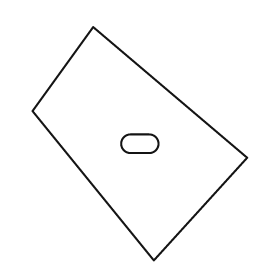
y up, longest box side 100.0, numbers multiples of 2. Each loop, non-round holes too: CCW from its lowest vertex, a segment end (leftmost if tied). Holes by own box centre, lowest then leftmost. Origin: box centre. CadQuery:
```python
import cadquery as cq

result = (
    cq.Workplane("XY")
    .moveTo(6.0, -50.0)
    .lineTo(46.0, -6.0)
    .lineTo(-20.0, 50.0)
    .lineTo(-46.0, 14.0)
    .close()
    .moveTo(-4.0, -4.0)
    .lineTo(4.0, -4.0)
    .threePointArc((8.0, 0.0), (4.0, 4.0))
    .lineTo(-4.0, 4.0)
    .threePointArc((-8.0, 0.0), (-4.0, -4.0))
    .close()
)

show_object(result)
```